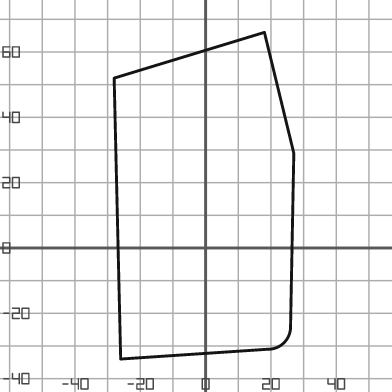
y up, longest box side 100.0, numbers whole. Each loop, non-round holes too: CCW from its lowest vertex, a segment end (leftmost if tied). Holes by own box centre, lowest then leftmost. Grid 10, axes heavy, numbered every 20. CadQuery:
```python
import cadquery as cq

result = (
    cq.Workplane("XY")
    .moveTo(-26.0, -34.0)
    .lineTo(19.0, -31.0)
    .threePointArc((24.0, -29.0), (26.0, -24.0))
    .lineTo(27.0, 29.0)
    .lineTo(18.0, 66.0)
    .lineTo(-28.0, 52.0)
    .close()
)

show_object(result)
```